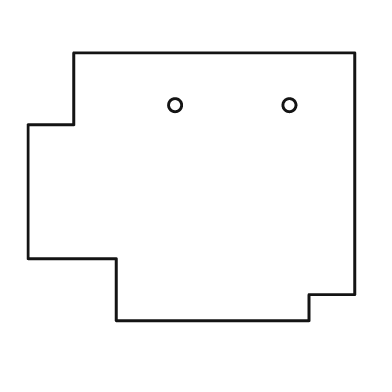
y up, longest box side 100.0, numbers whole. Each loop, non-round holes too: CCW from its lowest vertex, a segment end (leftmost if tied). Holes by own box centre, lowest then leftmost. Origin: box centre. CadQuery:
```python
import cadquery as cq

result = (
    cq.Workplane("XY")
    .moveTo(-23.0, -41.0)
    .lineTo(36.0, -41.0)
    .lineTo(36.0, -33.0)
    .lineTo(50.0, -33.0)
    .lineTo(50.0, 41.0)
    .lineTo(-36.0, 41.0)
    .lineTo(-36.0, 19.0)
    .lineTo(-50.0, 19.0)
    .lineTo(-50.0, -22.0)
    .lineTo(-23.0, -22.0)
    .close()
    .moveTo(-5.0, 25.0)
    .circle(2.0)
    .moveTo(30.0, 25.0)
    .circle(2.0)
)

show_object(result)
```